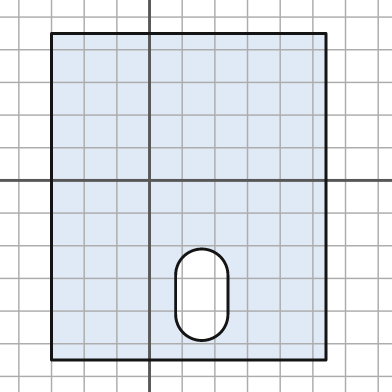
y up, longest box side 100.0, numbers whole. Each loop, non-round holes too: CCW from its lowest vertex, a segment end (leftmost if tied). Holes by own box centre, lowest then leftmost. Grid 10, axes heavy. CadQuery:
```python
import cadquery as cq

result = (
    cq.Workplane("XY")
    .moveTo(-30.0, -55.0)
    .lineTo(54.0, -55.0)
    .lineTo(54.0, 45.0)
    .lineTo(-30.0, 45.0)
    .close()
    .moveTo(8.0, -41.0)
    .threePointArc((16.0, -49.0), (24.0, -41.0))
    .lineTo(24.0, -29.0)
    .threePointArc((16.0, -21.0), (8.0, -29.0))
    .close()
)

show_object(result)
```